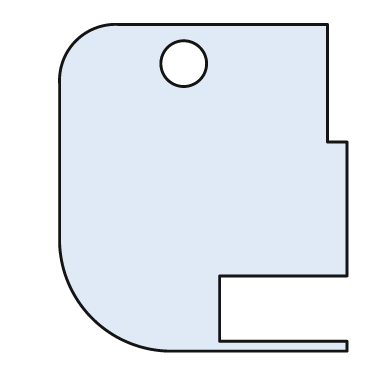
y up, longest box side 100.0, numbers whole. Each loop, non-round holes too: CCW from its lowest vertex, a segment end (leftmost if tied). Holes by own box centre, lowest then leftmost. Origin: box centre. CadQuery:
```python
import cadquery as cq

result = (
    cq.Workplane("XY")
    .moveTo(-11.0, -50.0)
    .lineTo(44.0, -50.0)
    .lineTo(44.0, -47.0)
    .lineTo(5.0, -47.0)
    .lineTo(5.0, -27.0)
    .lineTo(44.0, -27.0)
    .lineTo(44.0, 14.0)
    .lineTo(38.0, 14.0)
    .lineTo(38.0, 50.0)
    .lineTo(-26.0, 50.0)
    .threePointArc((-39.0, 45.0), (-44.0, 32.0))
    .lineTo(-44.0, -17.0)
    .threePointArc((-34.0, -40.0), (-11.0, -50.0))
    .close()
    .moveTo(-6.0, 38.0)
    .circle(7.0)
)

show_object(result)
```